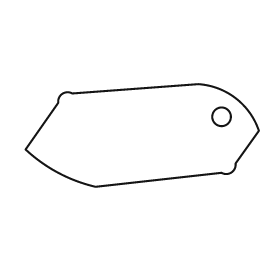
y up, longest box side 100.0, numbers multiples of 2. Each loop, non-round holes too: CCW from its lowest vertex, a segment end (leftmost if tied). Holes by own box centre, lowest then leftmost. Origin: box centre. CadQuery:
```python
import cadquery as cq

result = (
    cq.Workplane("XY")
    .moveTo(-20.0, -22.0)
    .lineTo(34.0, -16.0)
    .threePointArc((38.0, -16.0), (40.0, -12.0))
    .lineTo(50.0, 2.0)
    .threePointArc((40.0, 16.0), (24.0, 22.0))
    .lineTo(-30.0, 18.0)
    .threePointArc((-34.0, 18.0), (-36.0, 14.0))
    .lineTo(-50.0, -6.0)
    .threePointArc((-36.0, -16.0), (-20.0, -22.0))
    .close()
    .moveTo(34.0, 8.0)
    .circle(4.0)
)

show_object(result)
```